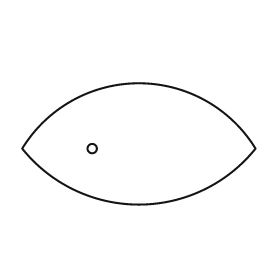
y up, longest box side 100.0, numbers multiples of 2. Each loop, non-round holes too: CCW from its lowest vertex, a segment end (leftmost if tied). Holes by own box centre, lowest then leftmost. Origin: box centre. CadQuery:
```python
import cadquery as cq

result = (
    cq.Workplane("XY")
    .moveTo(-50.0, -2.0)
    .threePointArc((0.0, -26.0), (50.0, -2.0))
    .threePointArc((0.0, 26.0), (-50.0, -2.0))
    .close()
    .moveTo(-20.0, -2.0)
    .circle(2.0)
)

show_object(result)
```